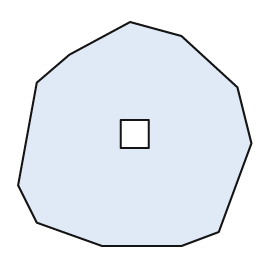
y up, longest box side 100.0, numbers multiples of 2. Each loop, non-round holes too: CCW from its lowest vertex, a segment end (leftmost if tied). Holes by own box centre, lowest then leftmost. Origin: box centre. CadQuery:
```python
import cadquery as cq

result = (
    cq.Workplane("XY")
    .moveTo(-14.0, -48.0)
    .lineTo(20.0, -48.0)
    .lineTo(36.0, -42.0)
    .lineTo(50.0, -4.0)
    .lineTo(44.0, 20.0)
    .lineTo(20.0, 42.0)
    .lineTo(-2.0, 48.0)
    .lineTo(-28.0, 34.0)
    .lineTo(-42.0, 22.0)
    .lineTo(-50.0, -22.0)
    .lineTo(-42.0, -38.0)
    .close()
    .moveTo(-6.0, -6.0)
    .lineTo(6.0, -6.0)
    .lineTo(6.0, 6.0)
    .lineTo(-6.0, 6.0)
    .close()
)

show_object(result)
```